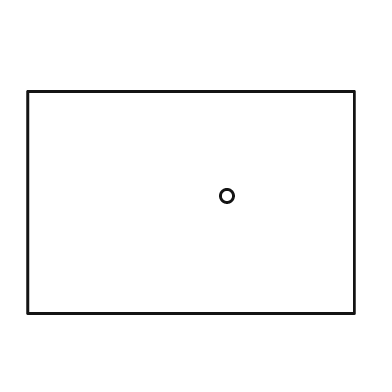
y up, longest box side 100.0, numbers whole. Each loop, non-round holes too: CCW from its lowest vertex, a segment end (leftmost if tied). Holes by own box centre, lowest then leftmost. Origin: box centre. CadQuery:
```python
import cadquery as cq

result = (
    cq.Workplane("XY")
    .moveTo(-50.0, -34.0)
    .lineTo(50.0, -34.0)
    .lineTo(50.0, 34.0)
    .lineTo(-50.0, 34.0)
    .close()
    .moveTo(11.0, 2.0)
    .circle(2.0)
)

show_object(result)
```